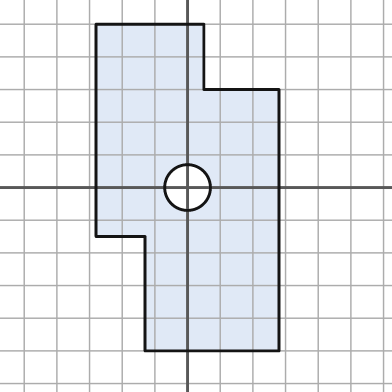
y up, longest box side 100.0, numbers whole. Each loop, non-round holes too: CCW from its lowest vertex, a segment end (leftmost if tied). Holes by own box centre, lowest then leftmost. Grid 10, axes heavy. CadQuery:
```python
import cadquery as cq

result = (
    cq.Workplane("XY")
    .moveTo(-13.0, -50.0)
    .lineTo(28.0, -50.0)
    .lineTo(28.0, 30.0)
    .lineTo(5.0, 30.0)
    .lineTo(5.0, 50.0)
    .lineTo(-28.0, 50.0)
    .lineTo(-28.0, -15.0)
    .lineTo(-13.0, -15.0)
    .close()
    .moveTo(0.0, 0.0)
    .circle(7.0)
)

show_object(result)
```